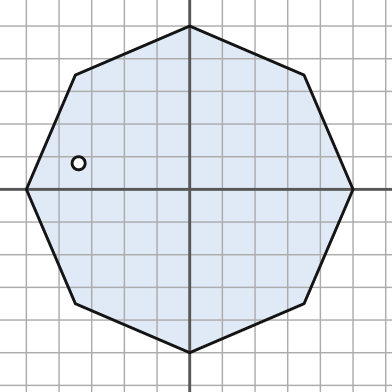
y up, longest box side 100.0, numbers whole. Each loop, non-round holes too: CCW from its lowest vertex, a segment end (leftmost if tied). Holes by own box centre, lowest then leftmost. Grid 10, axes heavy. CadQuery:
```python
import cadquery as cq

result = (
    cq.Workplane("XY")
    .moveTo(0.0, -50.0)
    .lineTo(35.0, -35.0)
    .lineTo(50.0, 0.0)
    .lineTo(35.0, 35.0)
    .lineTo(0.0, 50.0)
    .lineTo(-35.0, 35.0)
    .lineTo(-50.0, 0.0)
    .lineTo(-35.0, -35.0)
    .close()
    .moveTo(-34.0, 8.0)
    .circle(2.0)
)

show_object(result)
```